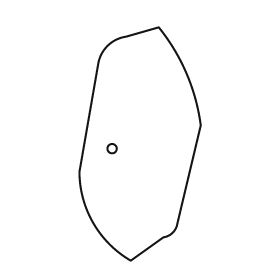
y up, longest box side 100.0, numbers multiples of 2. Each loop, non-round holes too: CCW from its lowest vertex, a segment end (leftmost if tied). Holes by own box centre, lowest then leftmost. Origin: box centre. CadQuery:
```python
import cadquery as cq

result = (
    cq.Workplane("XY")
    .moveTo(-4.0, -50.0)
    .lineTo(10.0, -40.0)
    .threePointArc((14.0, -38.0), (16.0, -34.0))
    .lineTo(26.0, 8.0)
    .threePointArc((20.0, 30.0), (8.0, 50.0))
    .lineTo(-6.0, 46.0)
    .threePointArc((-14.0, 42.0), (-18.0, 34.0))
    .lineTo(-26.0, -12.0)
    .threePointArc((-20.0, -34.0), (-4.0, -50.0))
    .close()
    .moveTo(-12.0, -2.0)
    .circle(2.0)
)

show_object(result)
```